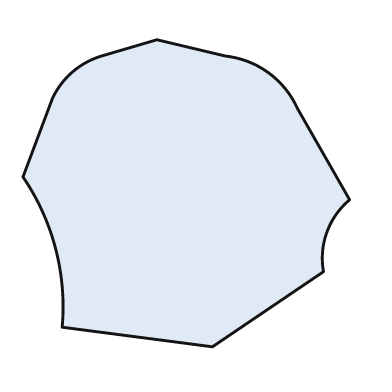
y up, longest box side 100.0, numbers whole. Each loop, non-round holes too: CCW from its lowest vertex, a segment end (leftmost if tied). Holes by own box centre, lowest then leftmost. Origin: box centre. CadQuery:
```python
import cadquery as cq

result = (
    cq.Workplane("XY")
    .moveTo(8.0, -47.0)
    .lineTo(42.0, -24.0)
    .threePointArc((43.0, -12.0), (50.0, -2.0))
    .lineTo(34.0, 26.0)
    .threePointArc((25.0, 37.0), (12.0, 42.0))
    .lineTo(-9.0, 47.0)
    .lineTo(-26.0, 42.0)
    .threePointArc((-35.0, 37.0), (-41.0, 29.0))
    .lineTo(-50.0, 5.0)
    .threePointArc((-40.0, -17.0), (-38.0, -41.0))
    .close()
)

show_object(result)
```